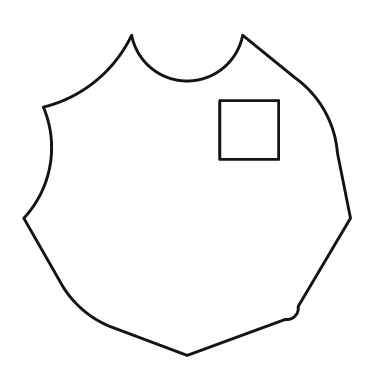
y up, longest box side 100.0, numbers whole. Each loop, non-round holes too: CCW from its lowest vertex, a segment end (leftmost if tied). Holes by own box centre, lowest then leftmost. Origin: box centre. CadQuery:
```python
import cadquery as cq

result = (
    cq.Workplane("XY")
    .moveTo(0.0, -49.0)
    .lineTo(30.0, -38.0)
    .threePointArc((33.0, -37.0), (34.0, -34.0))
    .lineTo(50.0, -7.0)
    .lineTo(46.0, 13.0)
    .threePointArc((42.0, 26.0), (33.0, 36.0))
    .lineTo(17.0, 49.0)
    .threePointArc((0.0, 35.0), (-17.0, 49.0))
    .threePointArc((-28.0, 35.0), (-44.0, 27.0))
    .threePointArc((-42.0, 9.0), (-50.0, -7.0))
    .lineTo(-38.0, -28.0)
    .threePointArc((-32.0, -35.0), (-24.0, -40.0))
    .close()
    .moveTo(10.0, 11.0)
    .lineTo(28.0, 11.0)
    .lineTo(28.0, 29.0)
    .lineTo(10.0, 29.0)
    .close()
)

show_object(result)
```